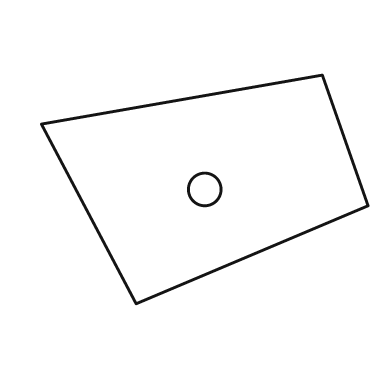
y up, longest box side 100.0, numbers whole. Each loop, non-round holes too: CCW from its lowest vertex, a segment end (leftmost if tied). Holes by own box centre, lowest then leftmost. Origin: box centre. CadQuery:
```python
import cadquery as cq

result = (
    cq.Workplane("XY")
    .moveTo(-21.0, -35.0)
    .lineTo(50.0, -5.0)
    .lineTo(36.0, 35.0)
    .lineTo(-50.0, 20.0)
    .close()
    .moveTo(0.0, 0.0)
    .circle(5.0)
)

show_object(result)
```